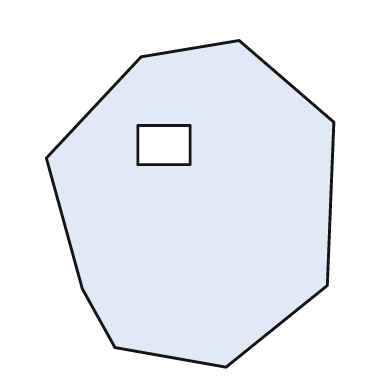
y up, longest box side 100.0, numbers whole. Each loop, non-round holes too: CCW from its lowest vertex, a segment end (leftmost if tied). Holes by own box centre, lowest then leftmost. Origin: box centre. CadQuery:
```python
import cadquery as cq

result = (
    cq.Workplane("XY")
    .moveTo(11.0, -50.0)
    .lineTo(42.0, -25.0)
    .lineTo(44.0, 25.0)
    .lineTo(15.0, 50.0)
    .lineTo(-15.0, 45.0)
    .lineTo(-44.0, 14.0)
    .lineTo(-33.0, -26.0)
    .lineTo(-23.0, -44.0)
    .close()
    .moveTo(-16.0, 12.0)
    .lineTo(0.0, 12.0)
    .lineTo(0.0, 24.0)
    .lineTo(-16.0, 24.0)
    .close()
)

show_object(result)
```